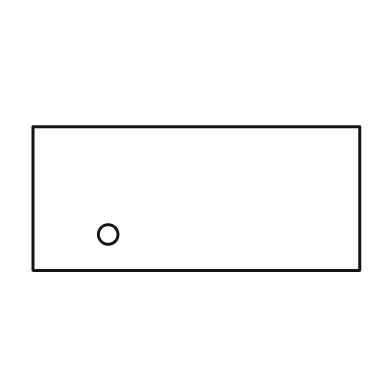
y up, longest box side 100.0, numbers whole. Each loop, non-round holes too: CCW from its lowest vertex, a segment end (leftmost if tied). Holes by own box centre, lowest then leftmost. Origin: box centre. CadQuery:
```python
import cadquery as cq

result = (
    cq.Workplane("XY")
    .moveTo(-50.0, -22.0)
    .lineTo(50.0, -22.0)
    .lineTo(50.0, 22.0)
    .lineTo(-50.0, 22.0)
    .close()
    .moveTo(-27.0, -11.0)
    .circle(3.0)
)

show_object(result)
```